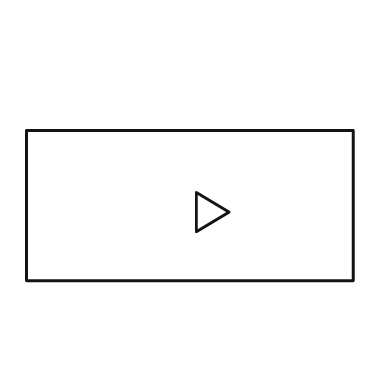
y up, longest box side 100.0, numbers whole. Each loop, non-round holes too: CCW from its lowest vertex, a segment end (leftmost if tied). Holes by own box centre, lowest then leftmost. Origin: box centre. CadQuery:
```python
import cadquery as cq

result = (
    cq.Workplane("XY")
    .moveTo(-50.0, -23.0)
    .lineTo(50.0, -23.0)
    .lineTo(50.0, 23.0)
    .lineTo(-50.0, 23.0)
    .close()
    .moveTo(2.0, -8.0)
    .lineTo(12.0, -2.0)
    .lineTo(2.0, 4.0)
    .close()
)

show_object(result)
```